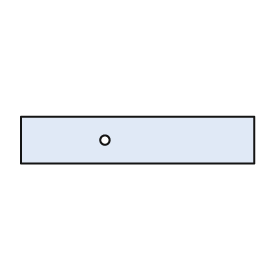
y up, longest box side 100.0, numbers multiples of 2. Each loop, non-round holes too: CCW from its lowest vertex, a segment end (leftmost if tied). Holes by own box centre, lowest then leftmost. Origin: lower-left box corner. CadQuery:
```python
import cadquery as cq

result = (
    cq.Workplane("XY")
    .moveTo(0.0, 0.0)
    .lineTo(100.0, 0.0)
    .lineTo(100.0, 20.0)
    .lineTo(0.0, 20.0)
    .close()
    .moveTo(36.0, 10.0)
    .circle(2.0)
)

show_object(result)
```